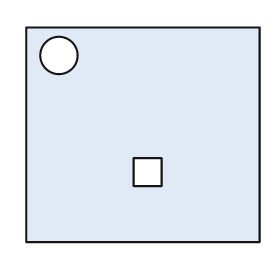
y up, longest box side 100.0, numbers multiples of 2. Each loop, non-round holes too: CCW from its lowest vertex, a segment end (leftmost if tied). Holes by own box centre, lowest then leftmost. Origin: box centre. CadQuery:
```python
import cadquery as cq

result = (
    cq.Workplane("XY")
    .moveTo(-50.0, -46.0)
    .lineTo(50.0, -46.0)
    .lineTo(50.0, 46.0)
    .lineTo(-50.0, 46.0)
    .close()
    .moveTo(-4.0, -22.0)
    .lineTo(8.0, -22.0)
    .lineTo(8.0, -10.0)
    .lineTo(-4.0, -10.0)
    .close()
    .moveTo(-36.0, 34.0)
    .circle(8.0)
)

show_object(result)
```